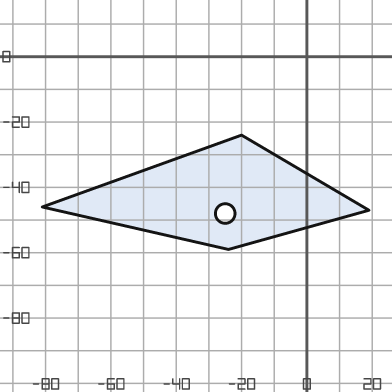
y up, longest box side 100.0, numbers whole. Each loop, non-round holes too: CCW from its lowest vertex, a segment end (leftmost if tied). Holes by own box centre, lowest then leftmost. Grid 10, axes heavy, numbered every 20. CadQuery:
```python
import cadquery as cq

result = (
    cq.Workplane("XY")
    .moveTo(-24.0, -59.0)
    .lineTo(19.0, -47.0)
    .lineTo(-20.0, -24.0)
    .lineTo(-81.0, -46.0)
    .close()
    .moveTo(-25.0, -48.0)
    .circle(3.0)
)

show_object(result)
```